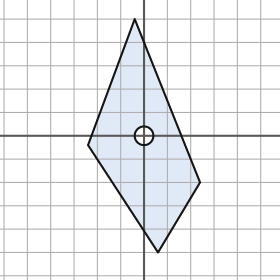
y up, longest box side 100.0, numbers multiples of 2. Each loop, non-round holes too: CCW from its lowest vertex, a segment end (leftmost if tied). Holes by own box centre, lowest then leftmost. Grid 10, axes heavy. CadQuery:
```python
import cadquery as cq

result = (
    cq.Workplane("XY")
    .moveTo(6.0, -50.0)
    .lineTo(24.0, -20.0)
    .lineTo(-4.0, 50.0)
    .lineTo(-24.0, -4.0)
    .close()
    .moveTo(0.0, 0.0)
    .circle(4.0)
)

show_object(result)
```